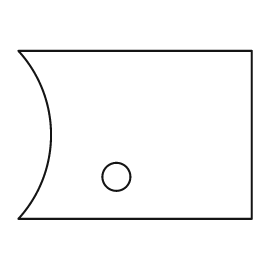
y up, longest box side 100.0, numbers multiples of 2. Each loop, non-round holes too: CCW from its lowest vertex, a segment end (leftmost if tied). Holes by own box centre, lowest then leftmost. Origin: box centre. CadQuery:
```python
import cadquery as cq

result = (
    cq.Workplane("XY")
    .moveTo(-50.0, -36.0)
    .lineTo(50.0, -36.0)
    .lineTo(50.0, 36.0)
    .lineTo(-50.0, 36.0)
    .threePointArc((-36.0, 0.0), (-50.0, -36.0))
    .close()
    .moveTo(-8.0, -18.0)
    .circle(6.0)
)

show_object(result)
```